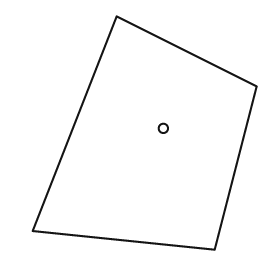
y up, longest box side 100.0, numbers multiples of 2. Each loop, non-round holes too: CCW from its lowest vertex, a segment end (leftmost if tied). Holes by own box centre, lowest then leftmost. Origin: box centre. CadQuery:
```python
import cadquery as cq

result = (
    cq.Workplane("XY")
    .moveTo(30.0, -50.0)
    .lineTo(48.0, 20.0)
    .lineTo(-12.0, 50.0)
    .lineTo(-48.0, -42.0)
    .close()
    .moveTo(8.0, 2.0)
    .circle(2.0)
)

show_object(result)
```